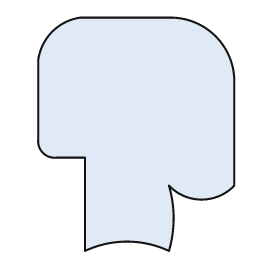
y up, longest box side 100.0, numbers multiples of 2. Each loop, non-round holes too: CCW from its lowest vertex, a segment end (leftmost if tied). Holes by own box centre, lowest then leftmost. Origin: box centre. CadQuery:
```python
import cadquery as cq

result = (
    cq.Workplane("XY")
    .moveTo(-22.0, -50.0)
    .threePointArc((-4.0, -46.0), (14.0, -50.0))
    .threePointArc((16.0, -36.0), (14.0, -22.0))
    .threePointArc((28.0, -28.0), (42.0, -22.0))
    .lineTo(42.0, 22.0)
    .threePointArc((34.0, 42.0), (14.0, 50.0))
    .lineTo(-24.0, 50.0)
    .threePointArc((-36.0, 44.0), (-42.0, 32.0))
    .lineTo(-42.0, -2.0)
    .threePointArc((-40.0, -8.0), (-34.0, -10.0))
    .lineTo(-22.0, -10.0)
    .close()
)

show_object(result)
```